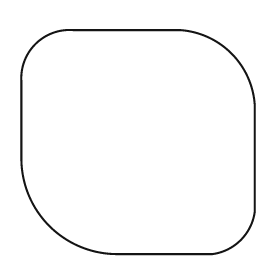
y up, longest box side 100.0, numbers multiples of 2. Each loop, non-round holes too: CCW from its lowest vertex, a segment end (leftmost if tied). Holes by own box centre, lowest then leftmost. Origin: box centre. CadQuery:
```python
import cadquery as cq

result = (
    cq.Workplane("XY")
    .moveTo(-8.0, -48.0)
    .lineTo(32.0, -48.0)
    .threePointArc((44.0, -42.0), (50.0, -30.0))
    .lineTo(50.0, 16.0)
    .threePointArc((40.0, 38.0), (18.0, 48.0))
    .lineTo(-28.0, 48.0)
    .threePointArc((-44.0, 42.0), (-50.0, 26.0))
    .lineTo(-50.0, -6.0)
    .threePointArc((-38.0, -36.0), (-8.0, -48.0))
    .close()
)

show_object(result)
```